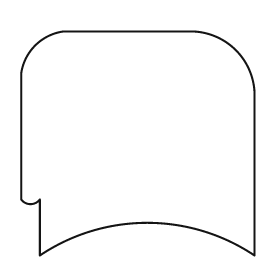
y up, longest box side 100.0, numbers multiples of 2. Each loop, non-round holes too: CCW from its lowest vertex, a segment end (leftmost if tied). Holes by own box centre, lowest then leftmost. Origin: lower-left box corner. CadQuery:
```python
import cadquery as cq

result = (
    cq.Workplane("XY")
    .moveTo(8.0, 0.0)
    .threePointArc((54.0, 14.0), (100.0, 0.0))
    .lineTo(100.0, 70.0)
    .threePointArc((92.0, 88.0), (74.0, 96.0))
    .lineTo(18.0, 96.0)
    .threePointArc((6.0, 90.0), (0.0, 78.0))
    .lineTo(0.0, 24.0)
    .threePointArc((4.0, 22.0), (8.0, 24.0))
    .close()
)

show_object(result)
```